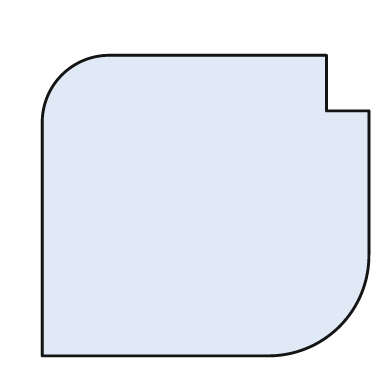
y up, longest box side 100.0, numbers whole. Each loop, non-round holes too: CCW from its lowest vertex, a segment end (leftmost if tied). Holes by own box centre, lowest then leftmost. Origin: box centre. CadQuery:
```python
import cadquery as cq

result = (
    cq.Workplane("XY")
    .moveTo(-50.0, -46.0)
    .lineTo(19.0, -46.0)
    .threePointArc((41.0, -37.0), (50.0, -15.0))
    .lineTo(50.0, 29.0)
    .lineTo(37.0, 29.0)
    .lineTo(37.0, 46.0)
    .lineTo(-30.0, 46.0)
    .threePointArc((-44.0, 40.0), (-50.0, 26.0))
    .close()
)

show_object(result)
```